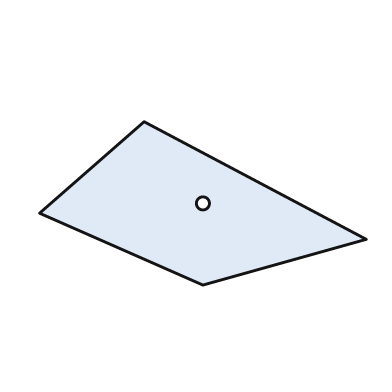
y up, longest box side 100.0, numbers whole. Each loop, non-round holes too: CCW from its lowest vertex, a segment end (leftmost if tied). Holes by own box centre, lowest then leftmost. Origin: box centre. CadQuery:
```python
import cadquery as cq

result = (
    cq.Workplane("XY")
    .moveTo(0.0, -25.0)
    .lineTo(50.0, -11.0)
    .lineTo(-18.0, 25.0)
    .lineTo(-50.0, -3.0)
    .close()
    .moveTo(0.0, 0.0)
    .circle(2.0)
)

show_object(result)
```